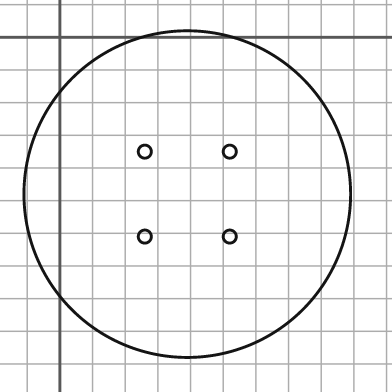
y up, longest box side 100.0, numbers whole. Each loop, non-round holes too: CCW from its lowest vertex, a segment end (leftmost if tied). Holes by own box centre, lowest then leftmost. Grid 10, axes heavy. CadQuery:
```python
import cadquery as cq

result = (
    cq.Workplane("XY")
    .moveTo(39.0, -48.0)
    .circle(50.0)
    .moveTo(26.0, -61.0)
    .circle(2.0)
    .moveTo(52.0, -61.0)
    .circle(2.0)
    .moveTo(26.0, -35.0)
    .circle(2.0)
    .moveTo(52.0, -35.0)
    .circle(2.0)
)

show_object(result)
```